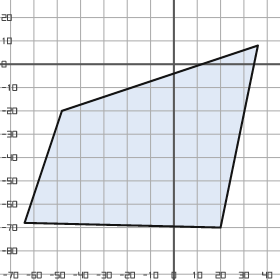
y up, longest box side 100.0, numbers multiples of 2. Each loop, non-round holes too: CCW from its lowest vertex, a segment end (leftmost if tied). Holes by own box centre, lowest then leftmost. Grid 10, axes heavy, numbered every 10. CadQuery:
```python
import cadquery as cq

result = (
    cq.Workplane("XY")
    .moveTo(20.0, -70.0)
    .lineTo(36.0, 8.0)
    .lineTo(-48.0, -20.0)
    .lineTo(-64.0, -68.0)
    .close()
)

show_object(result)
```